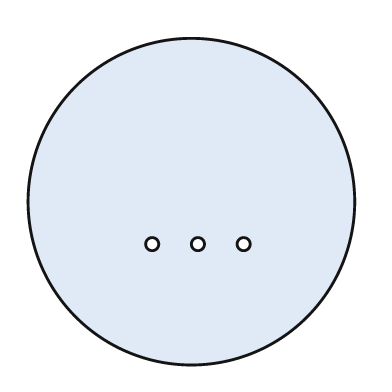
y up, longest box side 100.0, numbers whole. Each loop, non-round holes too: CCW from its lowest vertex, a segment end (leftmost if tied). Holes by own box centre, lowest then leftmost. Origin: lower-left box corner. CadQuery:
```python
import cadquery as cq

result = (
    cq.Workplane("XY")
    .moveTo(50.0, 50.0)
    .circle(50.0)
    .moveTo(38.0, 37.0)
    .circle(2.0)
    .moveTo(52.0, 37.0)
    .circle(2.0)
    .moveTo(66.0, 37.0)
    .circle(2.0)
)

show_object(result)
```